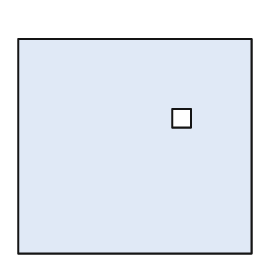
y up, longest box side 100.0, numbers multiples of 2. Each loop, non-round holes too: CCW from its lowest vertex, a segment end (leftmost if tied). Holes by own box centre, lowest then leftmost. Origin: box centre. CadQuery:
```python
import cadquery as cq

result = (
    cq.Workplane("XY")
    .moveTo(-50.0, -46.0)
    .lineTo(50.0, -46.0)
    .lineTo(50.0, 46.0)
    .lineTo(-50.0, 46.0)
    .close()
    .moveTo(16.0, 8.0)
    .lineTo(24.0, 8.0)
    .lineTo(24.0, 16.0)
    .lineTo(16.0, 16.0)
    .close()
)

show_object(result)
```